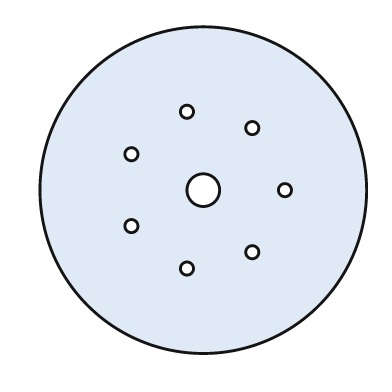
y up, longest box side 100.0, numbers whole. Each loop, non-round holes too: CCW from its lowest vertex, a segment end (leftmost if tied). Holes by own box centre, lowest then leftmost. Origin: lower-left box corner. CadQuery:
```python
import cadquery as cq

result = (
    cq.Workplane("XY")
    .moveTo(50.0, 50.0)
    .circle(50.0)
    .moveTo(45.0, 26.0)
    .circle(2.0)
    .moveTo(65.0, 31.0)
    .circle(2.0)
    .moveTo(28.0, 39.0)
    .circle(2.0)
    .moveTo(50.0, 50.0)
    .circle(5.0)
    .moveTo(75.0, 50.0)
    .circle(2.0)
    .moveTo(28.0, 61.0)
    .circle(2.0)
    .moveTo(65.0, 69.0)
    .circle(2.0)
    .moveTo(45.0, 74.0)
    .circle(2.0)
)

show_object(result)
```